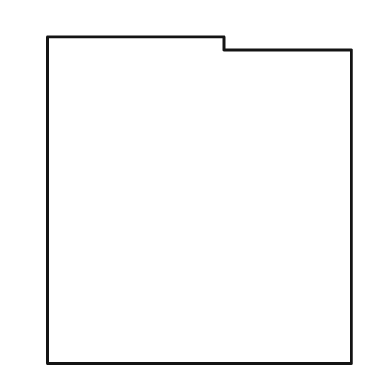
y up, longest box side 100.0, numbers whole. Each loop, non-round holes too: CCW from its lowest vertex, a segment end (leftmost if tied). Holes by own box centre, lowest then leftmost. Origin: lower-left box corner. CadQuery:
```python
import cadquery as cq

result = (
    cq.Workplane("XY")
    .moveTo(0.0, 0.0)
    .lineTo(93.0, 0.0)
    .lineTo(93.0, 96.0)
    .lineTo(54.0, 96.0)
    .lineTo(54.0, 100.0)
    .lineTo(0.0, 100.0)
    .close()
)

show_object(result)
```